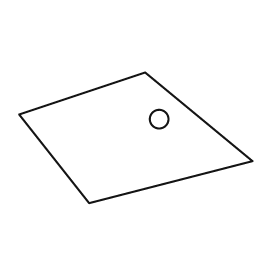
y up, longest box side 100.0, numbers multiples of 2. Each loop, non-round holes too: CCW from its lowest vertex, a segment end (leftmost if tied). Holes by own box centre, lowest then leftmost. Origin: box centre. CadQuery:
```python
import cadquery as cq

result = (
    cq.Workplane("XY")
    .moveTo(-20.0, -28.0)
    .lineTo(50.0, -10.0)
    .lineTo(4.0, 28.0)
    .lineTo(-50.0, 10.0)
    .close()
    .moveTo(10.0, 8.0)
    .circle(4.0)
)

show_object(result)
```